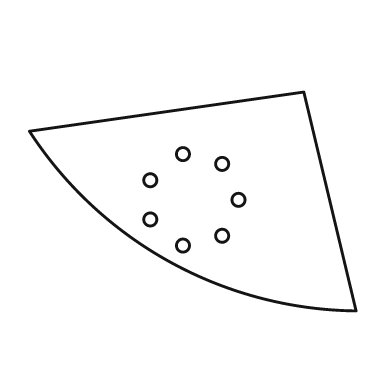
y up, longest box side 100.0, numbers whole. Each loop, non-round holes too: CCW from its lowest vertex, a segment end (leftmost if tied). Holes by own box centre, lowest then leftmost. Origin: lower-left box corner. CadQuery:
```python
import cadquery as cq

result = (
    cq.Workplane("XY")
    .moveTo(100.0, 0.0)
    .lineTo(84.0, 67.0)
    .lineTo(0.0, 55.0)
    .threePointArc((43.0, 15.0), (100.0, 0.0))
    .close()
    .moveTo(47.0, 20.0)
    .circle(2.0)
    .moveTo(59.0, 23.0)
    .circle(2.0)
    .moveTo(37.0, 28.0)
    .circle(2.0)
    .moveTo(64.0, 34.0)
    .circle(2.0)
    .moveTo(37.0, 40.0)
    .circle(2.0)
    .moveTo(59.0, 45.0)
    .circle(2.0)
    .moveTo(47.0, 48.0)
    .circle(2.0)
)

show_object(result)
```